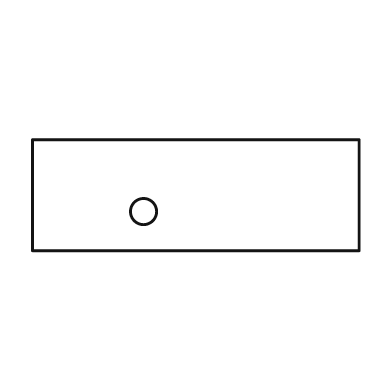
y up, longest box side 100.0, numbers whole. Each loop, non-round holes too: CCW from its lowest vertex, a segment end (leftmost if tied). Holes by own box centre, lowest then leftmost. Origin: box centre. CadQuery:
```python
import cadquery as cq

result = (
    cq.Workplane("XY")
    .moveTo(-50.0, -17.0)
    .lineTo(50.0, -17.0)
    .lineTo(50.0, 17.0)
    .lineTo(-50.0, 17.0)
    .close()
    .moveTo(-16.0, -5.0)
    .circle(4.0)
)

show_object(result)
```